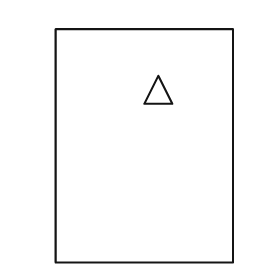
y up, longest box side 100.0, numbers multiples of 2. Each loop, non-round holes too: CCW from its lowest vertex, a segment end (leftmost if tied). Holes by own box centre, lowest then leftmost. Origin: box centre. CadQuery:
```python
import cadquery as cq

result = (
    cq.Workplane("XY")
    .moveTo(-38.0, -50.0)
    .lineTo(38.0, -50.0)
    .lineTo(38.0, 50.0)
    .lineTo(-38.0, 50.0)
    .close()
    .moveTo(0.0, 18.0)
    .lineTo(12.0, 18.0)
    .lineTo(6.0, 30.0)
    .close()
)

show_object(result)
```